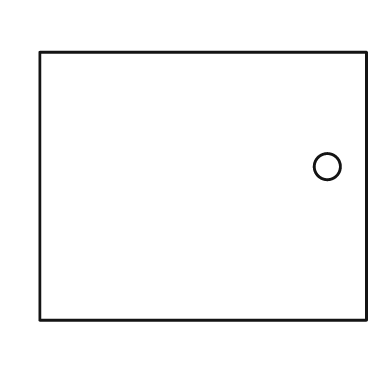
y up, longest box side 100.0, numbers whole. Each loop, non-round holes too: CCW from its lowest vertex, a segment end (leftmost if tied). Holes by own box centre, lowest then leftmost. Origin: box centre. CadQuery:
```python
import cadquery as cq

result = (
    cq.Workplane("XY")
    .moveTo(-50.0, -41.0)
    .lineTo(50.0, -41.0)
    .lineTo(50.0, 41.0)
    .lineTo(-50.0, 41.0)
    .close()
    .moveTo(38.0, 6.0)
    .circle(4.0)
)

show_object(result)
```